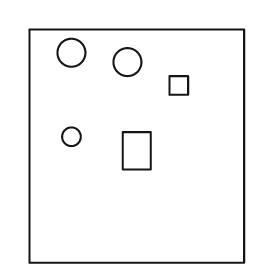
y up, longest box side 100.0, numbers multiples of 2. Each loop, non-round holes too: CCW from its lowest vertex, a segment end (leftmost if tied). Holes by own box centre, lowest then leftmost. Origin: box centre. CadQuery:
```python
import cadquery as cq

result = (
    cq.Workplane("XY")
    .moveTo(-46.0, -50.0)
    .lineTo(46.0, -50.0)
    .lineTo(46.0, 50.0)
    .lineTo(-46.0, 50.0)
    .close()
    .moveTo(-6.0, -10.0)
    .lineTo(6.0, -10.0)
    .lineTo(6.0, 6.0)
    .lineTo(-6.0, 6.0)
    .close()
    .moveTo(-28.0, 4.0)
    .circle(4.0)
    .moveTo(14.0, 22.0)
    .lineTo(22.0, 22.0)
    .lineTo(22.0, 30.0)
    .lineTo(14.0, 30.0)
    .close()
    .moveTo(-4.0, 36.0)
    .circle(6.0)
    .moveTo(-28.0, 40.0)
    .circle(6.0)
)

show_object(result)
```